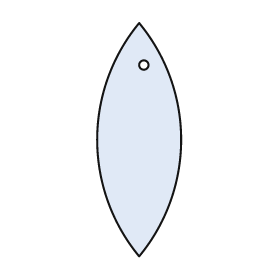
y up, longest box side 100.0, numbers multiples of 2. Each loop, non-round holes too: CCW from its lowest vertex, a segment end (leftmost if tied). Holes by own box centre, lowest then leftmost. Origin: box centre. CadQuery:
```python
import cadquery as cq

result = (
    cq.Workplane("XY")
    .moveTo(0.0, -50.0)
    .threePointArc((18.0, 0.0), (0.0, 50.0))
    .threePointArc((-18.0, 0.0), (0.0, -50.0))
    .close()
    .moveTo(2.0, 32.0)
    .circle(2.0)
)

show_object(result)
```